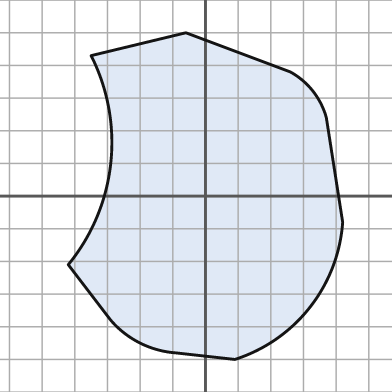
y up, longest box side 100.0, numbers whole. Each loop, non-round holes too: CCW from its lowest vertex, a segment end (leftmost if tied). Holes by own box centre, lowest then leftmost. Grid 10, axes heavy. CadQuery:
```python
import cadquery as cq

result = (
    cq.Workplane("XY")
    .moveTo(9.0, -50.0)
    .threePointArc((32.0, -34.0), (42.0, -8.0))
    .lineTo(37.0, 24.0)
    .threePointArc((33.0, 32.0), (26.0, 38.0))
    .lineTo(-6.0, 50.0)
    .lineTo(-35.0, 43.0)
    .threePointArc((-29.0, 10.0), (-42.0, -21.0))
    .lineTo(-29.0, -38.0)
    .threePointArc((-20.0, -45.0), (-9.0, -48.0))
    .close()
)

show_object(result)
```